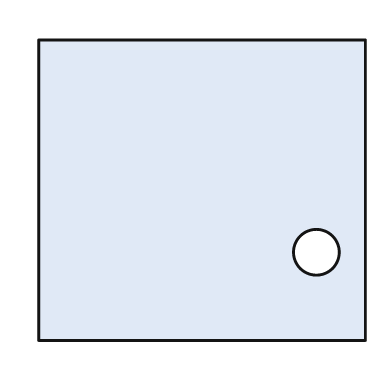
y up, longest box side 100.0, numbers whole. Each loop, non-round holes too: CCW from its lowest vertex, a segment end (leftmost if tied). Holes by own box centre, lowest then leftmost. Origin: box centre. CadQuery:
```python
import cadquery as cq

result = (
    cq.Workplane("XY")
    .moveTo(-50.0, -46.0)
    .lineTo(50.0, -46.0)
    .lineTo(50.0, 46.0)
    .lineTo(-50.0, 46.0)
    .close()
    .moveTo(35.0, -19.0)
    .circle(7.0)
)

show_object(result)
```